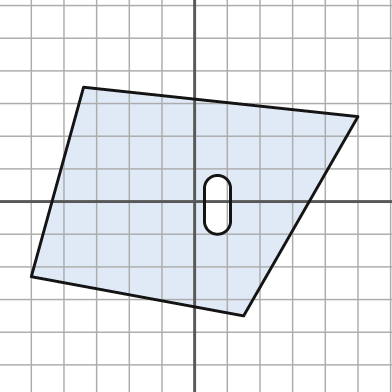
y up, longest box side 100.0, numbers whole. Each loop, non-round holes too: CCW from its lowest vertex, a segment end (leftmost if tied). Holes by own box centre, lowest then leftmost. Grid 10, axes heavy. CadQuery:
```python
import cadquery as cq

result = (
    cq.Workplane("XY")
    .moveTo(15.0, -35.0)
    .lineTo(50.0, 26.0)
    .lineTo(-34.0, 35.0)
    .lineTo(-50.0, -23.0)
    .close()
    .moveTo(3.0, -6.0)
    .threePointArc((7.0, -10.0), (11.0, -6.0))
    .lineTo(11.0, 4.0)
    .threePointArc((7.0, 8.0), (3.0, 4.0))
    .close()
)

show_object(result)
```